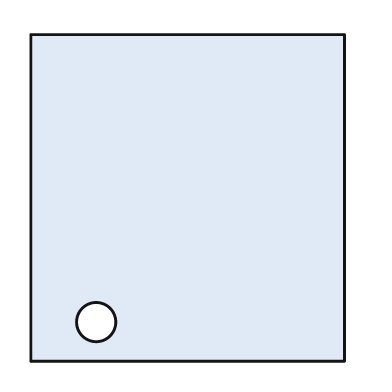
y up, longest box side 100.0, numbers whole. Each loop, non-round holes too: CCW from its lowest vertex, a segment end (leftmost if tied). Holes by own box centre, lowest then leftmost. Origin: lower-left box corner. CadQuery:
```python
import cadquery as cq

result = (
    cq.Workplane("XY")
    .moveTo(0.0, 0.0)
    .lineTo(96.0, 0.0)
    .lineTo(96.0, 100.0)
    .lineTo(0.0, 100.0)
    .close()
    .moveTo(20.0, 12.0)
    .circle(6.0)
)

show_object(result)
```